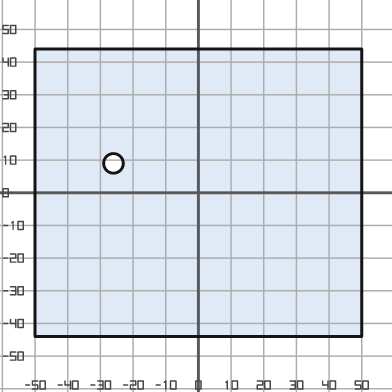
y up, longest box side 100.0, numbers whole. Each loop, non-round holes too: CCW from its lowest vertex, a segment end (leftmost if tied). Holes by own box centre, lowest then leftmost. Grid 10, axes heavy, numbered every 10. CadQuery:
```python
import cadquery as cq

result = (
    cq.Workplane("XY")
    .moveTo(-50.0, -44.0)
    .lineTo(50.0, -44.0)
    .lineTo(50.0, 44.0)
    .lineTo(-50.0, 44.0)
    .close()
    .moveTo(-26.0, 9.0)
    .circle(3.0)
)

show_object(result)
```